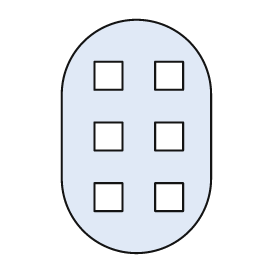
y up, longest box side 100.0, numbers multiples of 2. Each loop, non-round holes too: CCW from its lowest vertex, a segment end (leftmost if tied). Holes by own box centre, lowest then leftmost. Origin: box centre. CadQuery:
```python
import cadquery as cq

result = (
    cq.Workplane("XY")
    .moveTo(-32.0, -18.0)
    .threePointArc((0.0, -50.0), (32.0, -18.0))
    .lineTo(32.0, 18.0)
    .threePointArc((0.0, 50.0), (-32.0, 18.0))
    .close()
    .moveTo(-18.0, -32.0)
    .lineTo(-6.0, -32.0)
    .lineTo(-6.0, -20.0)
    .lineTo(-18.0, -20.0)
    .close()
    .moveTo(8.0, -32.0)
    .lineTo(20.0, -32.0)
    .lineTo(20.0, -20.0)
    .lineTo(8.0, -20.0)
    .close()
    .moveTo(-18.0, -6.0)
    .lineTo(-6.0, -6.0)
    .lineTo(-6.0, 6.0)
    .lineTo(-18.0, 6.0)
    .close()
    .moveTo(8.0, -6.0)
    .lineTo(20.0, -6.0)
    .lineTo(20.0, 6.0)
    .lineTo(8.0, 6.0)
    .close()
    .moveTo(-18.0, 20.0)
    .lineTo(-6.0, 20.0)
    .lineTo(-6.0, 32.0)
    .lineTo(-18.0, 32.0)
    .close()
    .moveTo(8.0, 20.0)
    .lineTo(20.0, 20.0)
    .lineTo(20.0, 32.0)
    .lineTo(8.0, 32.0)
    .close()
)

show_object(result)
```